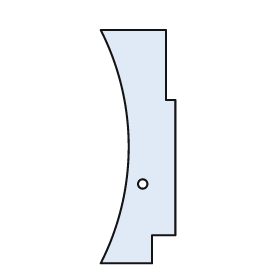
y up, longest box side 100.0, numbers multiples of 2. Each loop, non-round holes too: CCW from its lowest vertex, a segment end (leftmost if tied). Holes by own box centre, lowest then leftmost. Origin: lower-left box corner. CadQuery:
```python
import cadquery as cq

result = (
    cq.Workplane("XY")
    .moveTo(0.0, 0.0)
    .lineTo(22.0, 0.0)
    .lineTo(22.0, 12.0)
    .lineTo(32.0, 12.0)
    .lineTo(32.0, 70.0)
    .lineTo(28.0, 70.0)
    .lineTo(28.0, 100.0)
    .lineTo(0.0, 100.0)
    .threePointArc((12.0, 50.0), (0.0, 0.0))
    .close()
    .moveTo(18.0, 34.0)
    .circle(2.0)
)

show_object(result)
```